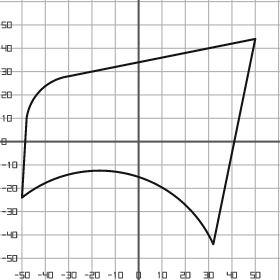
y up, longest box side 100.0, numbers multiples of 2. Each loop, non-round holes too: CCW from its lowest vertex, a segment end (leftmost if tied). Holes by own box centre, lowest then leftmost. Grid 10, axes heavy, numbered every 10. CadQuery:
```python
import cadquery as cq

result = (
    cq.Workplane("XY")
    .moveTo(32.0, -44.0)
    .lineTo(50.0, 44.0)
    .lineTo(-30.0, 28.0)
    .threePointArc((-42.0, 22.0), (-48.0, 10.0))
    .lineTo(-50.0, -24.0)
    .threePointArc((-4.0, -14.0), (32.0, -44.0))
    .close()
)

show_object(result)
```